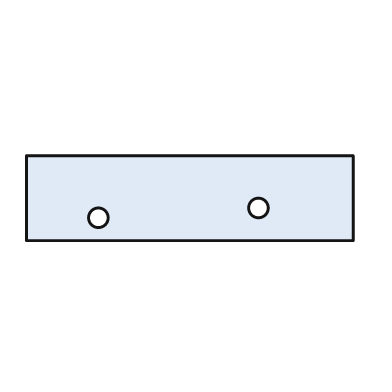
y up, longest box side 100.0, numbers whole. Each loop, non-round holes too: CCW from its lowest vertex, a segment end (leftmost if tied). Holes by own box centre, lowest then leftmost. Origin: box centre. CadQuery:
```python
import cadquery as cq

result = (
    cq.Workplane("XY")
    .moveTo(-50.0, -13.0)
    .lineTo(50.0, -13.0)
    .lineTo(50.0, 13.0)
    .lineTo(-50.0, 13.0)
    .close()
    .moveTo(-28.0, -6.0)
    .circle(3.0)
    .moveTo(21.0, -3.0)
    .circle(3.0)
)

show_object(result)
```